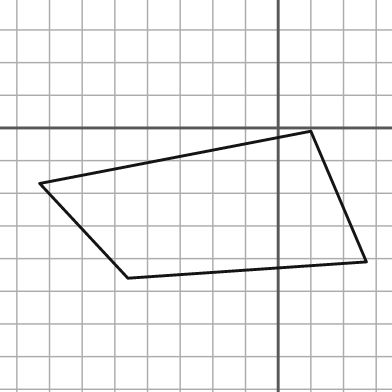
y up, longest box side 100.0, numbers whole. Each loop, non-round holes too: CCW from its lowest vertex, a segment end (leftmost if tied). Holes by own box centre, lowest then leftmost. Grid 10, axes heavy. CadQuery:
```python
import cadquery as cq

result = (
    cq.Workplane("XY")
    .moveTo(-46.0, -46.0)
    .lineTo(27.0, -41.0)
    .lineTo(10.0, -1.0)
    .lineTo(-73.0, -17.0)
    .close()
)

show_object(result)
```